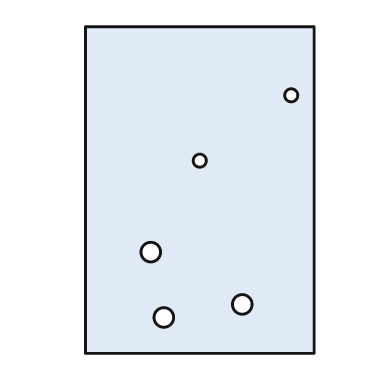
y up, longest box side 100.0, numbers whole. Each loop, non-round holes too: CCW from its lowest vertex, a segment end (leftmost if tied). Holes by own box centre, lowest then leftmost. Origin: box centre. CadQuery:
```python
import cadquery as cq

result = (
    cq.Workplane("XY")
    .moveTo(-35.0, -50.0)
    .lineTo(35.0, -50.0)
    .lineTo(35.0, 50.0)
    .lineTo(-35.0, 50.0)
    .close()
    .moveTo(-11.0, -39.0)
    .circle(3.0)
    .moveTo(13.0, -35.0)
    .circle(3.0)
    .moveTo(-15.0, -19.0)
    .circle(3.0)
    .moveTo(0.0, 9.0)
    .circle(2.0)
    .moveTo(28.0, 29.0)
    .circle(2.0)
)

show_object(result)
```